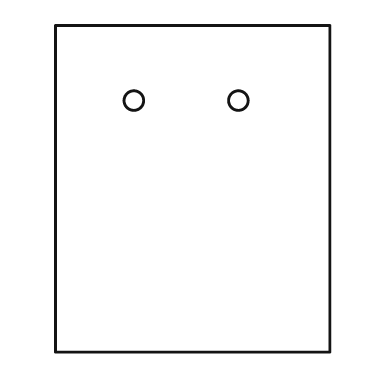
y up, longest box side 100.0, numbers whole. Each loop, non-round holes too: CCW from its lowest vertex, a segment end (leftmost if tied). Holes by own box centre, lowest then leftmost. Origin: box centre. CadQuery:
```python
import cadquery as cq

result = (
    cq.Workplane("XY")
    .moveTo(-42.0, -50.0)
    .lineTo(42.0, -50.0)
    .lineTo(42.0, 50.0)
    .lineTo(-42.0, 50.0)
    .close()
    .moveTo(-18.0, 27.0)
    .circle(3.0)
    .moveTo(14.0, 27.0)
    .circle(3.0)
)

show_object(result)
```